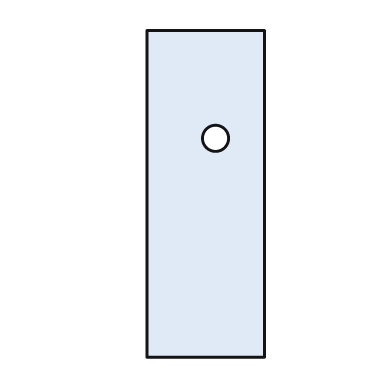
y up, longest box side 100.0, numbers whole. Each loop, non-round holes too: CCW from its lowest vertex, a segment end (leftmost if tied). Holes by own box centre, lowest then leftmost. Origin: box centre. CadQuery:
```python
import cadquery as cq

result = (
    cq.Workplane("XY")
    .moveTo(-18.0, -50.0)
    .lineTo(18.0, -50.0)
    .lineTo(18.0, 50.0)
    .lineTo(-18.0, 50.0)
    .close()
    .moveTo(3.0, 17.0)
    .circle(4.0)
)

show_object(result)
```